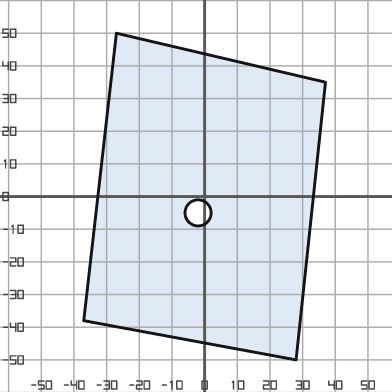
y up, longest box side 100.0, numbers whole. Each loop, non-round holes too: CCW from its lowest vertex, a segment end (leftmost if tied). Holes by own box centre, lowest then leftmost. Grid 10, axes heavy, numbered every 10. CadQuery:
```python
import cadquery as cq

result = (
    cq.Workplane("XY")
    .moveTo(28.0, -50.0)
    .lineTo(37.0, 35.0)
    .lineTo(-27.0, 50.0)
    .lineTo(-37.0, -38.0)
    .close()
    .moveTo(-2.0, -5.0)
    .circle(4.0)
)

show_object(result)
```